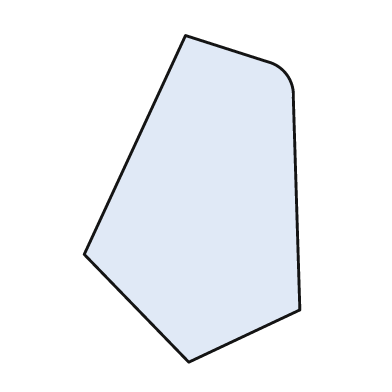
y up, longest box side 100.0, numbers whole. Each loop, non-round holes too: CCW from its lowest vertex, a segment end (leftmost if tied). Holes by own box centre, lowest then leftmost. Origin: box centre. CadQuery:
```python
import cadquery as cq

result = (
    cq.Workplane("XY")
    .moveTo(-1.0, -50.0)
    .lineTo(33.0, -34.0)
    .lineTo(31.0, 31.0)
    .threePointArc((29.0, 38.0), (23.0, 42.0))
    .lineTo(-2.0, 50.0)
    .lineTo(-33.0, -17.0)
    .close()
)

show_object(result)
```